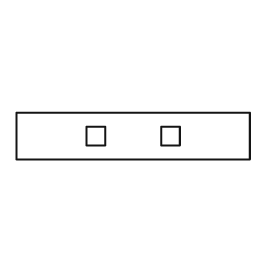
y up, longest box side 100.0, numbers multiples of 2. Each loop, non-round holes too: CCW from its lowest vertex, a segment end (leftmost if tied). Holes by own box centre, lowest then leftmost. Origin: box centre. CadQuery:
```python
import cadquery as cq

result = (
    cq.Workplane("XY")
    .moveTo(-50.0, -10.0)
    .lineTo(50.0, -10.0)
    .lineTo(50.0, 10.0)
    .lineTo(-50.0, 10.0)
    .close()
    .moveTo(-20.0, -4.0)
    .lineTo(-12.0, -4.0)
    .lineTo(-12.0, 4.0)
    .lineTo(-20.0, 4.0)
    .close()
    .moveTo(12.0, -4.0)
    .lineTo(20.0, -4.0)
    .lineTo(20.0, 4.0)
    .lineTo(12.0, 4.0)
    .close()
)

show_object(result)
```